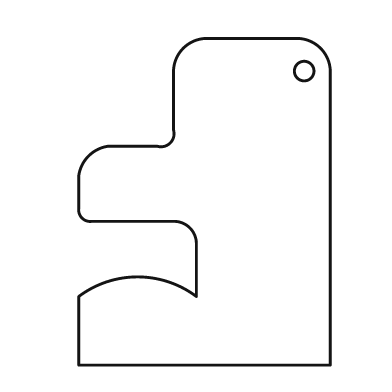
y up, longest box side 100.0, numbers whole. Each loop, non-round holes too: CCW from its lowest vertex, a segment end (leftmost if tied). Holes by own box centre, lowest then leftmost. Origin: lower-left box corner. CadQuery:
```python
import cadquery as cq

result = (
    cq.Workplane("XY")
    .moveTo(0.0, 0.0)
    .lineTo(77.0, 0.0)
    .lineTo(77.0, 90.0)
    .threePointArc((74.0, 97.0), (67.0, 100.0))
    .lineTo(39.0, 100.0)
    .threePointArc((32.0, 97.0), (29.0, 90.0))
    .lineTo(29.0, 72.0)
    .threePointArc((28.0, 68.0), (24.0, 67.0))
    .lineTo(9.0, 67.0)
    .threePointArc((3.0, 64.0), (0.0, 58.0))
    .lineTo(0.0, 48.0)
    .threePointArc((1.0, 45.0), (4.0, 44.0))
    .lineTo(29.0, 44.0)
    .threePointArc((34.0, 42.0), (36.0, 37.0))
    .lineTo(36.0, 21.0)
    .threePointArc((18.0, 27.0), (0.0, 21.0))
    .close()
    .moveTo(69.0, 90.0)
    .circle(3.0)
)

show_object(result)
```